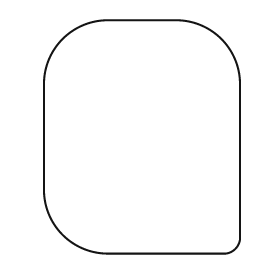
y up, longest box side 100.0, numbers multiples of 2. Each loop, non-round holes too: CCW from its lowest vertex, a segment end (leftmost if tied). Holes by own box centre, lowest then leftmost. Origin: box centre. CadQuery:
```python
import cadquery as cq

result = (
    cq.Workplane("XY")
    .moveTo(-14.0, -50.0)
    .lineTo(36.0, -50.0)
    .threePointArc((40.0, -48.0), (42.0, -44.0))
    .lineTo(42.0, 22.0)
    .threePointArc((34.0, 42.0), (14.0, 50.0))
    .lineTo(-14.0, 50.0)
    .threePointArc((-34.0, 42.0), (-42.0, 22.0))
    .lineTo(-42.0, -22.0)
    .threePointArc((-34.0, -42.0), (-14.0, -50.0))
    .close()
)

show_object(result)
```